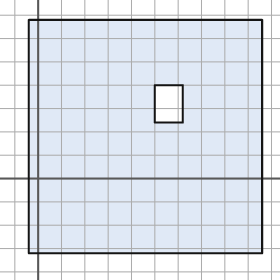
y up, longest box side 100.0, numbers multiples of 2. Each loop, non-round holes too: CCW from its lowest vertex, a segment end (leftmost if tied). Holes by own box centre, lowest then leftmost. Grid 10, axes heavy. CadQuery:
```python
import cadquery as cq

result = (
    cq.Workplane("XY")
    .moveTo(-4.0, -32.0)
    .lineTo(96.0, -32.0)
    .lineTo(96.0, 68.0)
    .lineTo(-4.0, 68.0)
    .close()
    .moveTo(50.0, 24.0)
    .lineTo(62.0, 24.0)
    .lineTo(62.0, 40.0)
    .lineTo(50.0, 40.0)
    .close()
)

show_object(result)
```